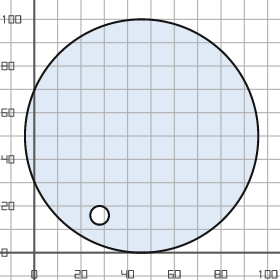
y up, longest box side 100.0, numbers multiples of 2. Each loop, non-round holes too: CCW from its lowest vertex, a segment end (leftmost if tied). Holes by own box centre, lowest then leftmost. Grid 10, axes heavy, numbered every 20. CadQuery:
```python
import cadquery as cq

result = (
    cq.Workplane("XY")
    .moveTo(46.0, 50.0)
    .circle(50.0)
    .moveTo(28.0, 16.0)
    .circle(4.0)
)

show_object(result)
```